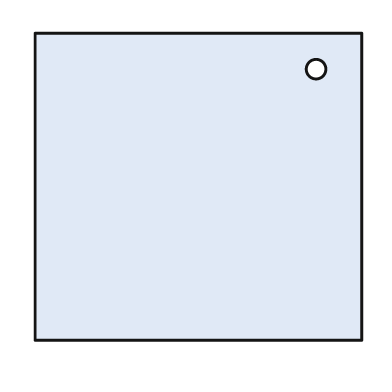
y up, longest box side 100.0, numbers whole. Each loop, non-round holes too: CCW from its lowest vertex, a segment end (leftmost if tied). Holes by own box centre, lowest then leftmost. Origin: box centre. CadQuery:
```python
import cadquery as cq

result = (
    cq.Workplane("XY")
    .moveTo(-50.0, -47.0)
    .lineTo(50.0, -47.0)
    .lineTo(50.0, 47.0)
    .lineTo(-50.0, 47.0)
    .close()
    .moveTo(36.0, 36.0)
    .circle(3.0)
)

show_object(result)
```